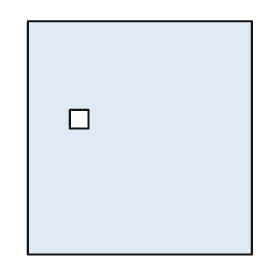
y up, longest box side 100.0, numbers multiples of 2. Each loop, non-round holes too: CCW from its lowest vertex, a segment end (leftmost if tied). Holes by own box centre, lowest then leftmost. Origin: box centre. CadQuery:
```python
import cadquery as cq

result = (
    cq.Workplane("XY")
    .moveTo(-48.0, -50.0)
    .lineTo(48.0, -50.0)
    .lineTo(48.0, 50.0)
    .lineTo(-48.0, 50.0)
    .close()
    .moveTo(-30.0, 4.0)
    .lineTo(-22.0, 4.0)
    .lineTo(-22.0, 12.0)
    .lineTo(-30.0, 12.0)
    .close()
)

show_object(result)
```